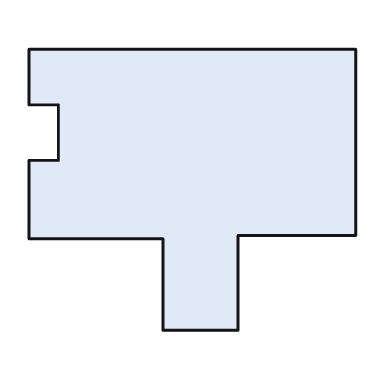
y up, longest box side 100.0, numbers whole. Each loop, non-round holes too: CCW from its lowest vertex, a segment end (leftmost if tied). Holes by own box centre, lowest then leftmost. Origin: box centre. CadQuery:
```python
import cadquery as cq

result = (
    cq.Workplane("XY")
    .moveTo(-9.0, -43.0)
    .lineTo(14.0, -43.0)
    .lineTo(14.0, -14.0)
    .lineTo(50.0, -14.0)
    .lineTo(50.0, 43.0)
    .lineTo(-50.0, 43.0)
    .lineTo(-50.0, 26.0)
    .lineTo(-41.0, 26.0)
    .lineTo(-41.0, 9.0)
    .lineTo(-50.0, 9.0)
    .lineTo(-50.0, -15.0)
    .lineTo(-9.0, -15.0)
    .close()
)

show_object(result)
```